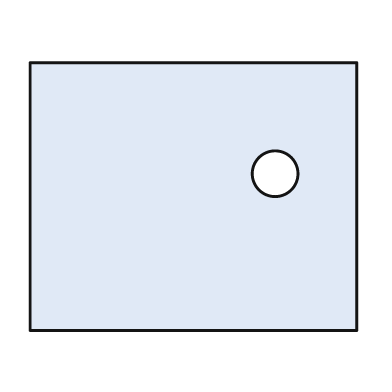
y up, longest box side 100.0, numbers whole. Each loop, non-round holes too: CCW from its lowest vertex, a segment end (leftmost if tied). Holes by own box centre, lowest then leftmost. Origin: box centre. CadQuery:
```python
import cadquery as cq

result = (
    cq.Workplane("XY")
    .moveTo(-50.0, -41.0)
    .lineTo(50.0, -41.0)
    .lineTo(50.0, 41.0)
    .lineTo(-50.0, 41.0)
    .close()
    .moveTo(25.0, 7.0)
    .circle(7.0)
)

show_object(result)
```